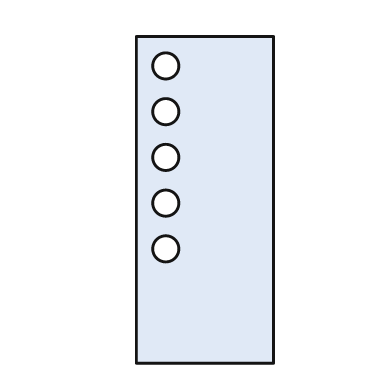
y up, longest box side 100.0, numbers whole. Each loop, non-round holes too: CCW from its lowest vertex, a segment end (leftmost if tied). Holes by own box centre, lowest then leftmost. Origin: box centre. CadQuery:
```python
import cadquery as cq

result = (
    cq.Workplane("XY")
    .moveTo(-21.0, -50.0)
    .lineTo(21.0, -50.0)
    .lineTo(21.0, 50.0)
    .lineTo(-21.0, 50.0)
    .close()
    .moveTo(-12.0, -15.0)
    .circle(4.0)
    .moveTo(-12.0, -1.0)
    .circle(4.0)
    .moveTo(-12.0, 13.0)
    .circle(4.0)
    .moveTo(-12.0, 27.0)
    .circle(4.0)
    .moveTo(-12.0, 41.0)
    .circle(4.0)
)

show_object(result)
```